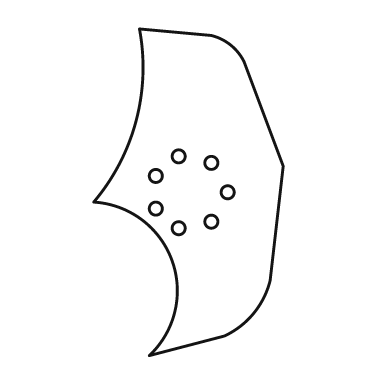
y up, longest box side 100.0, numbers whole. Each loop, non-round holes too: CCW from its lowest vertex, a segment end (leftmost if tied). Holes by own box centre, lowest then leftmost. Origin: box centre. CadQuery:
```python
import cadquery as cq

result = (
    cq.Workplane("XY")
    .moveTo(-12.0, -50.0)
    .lineTo(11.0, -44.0)
    .threePointArc((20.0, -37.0), (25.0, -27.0))
    .lineTo(29.0, 8.0)
    .lineTo(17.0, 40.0)
    .threePointArc((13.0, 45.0), (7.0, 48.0))
    .lineTo(-15.0, 50.0)
    .threePointArc((-16.0, 22.0), (-29.0, -3.0))
    .threePointArc((-5.0, -21.0), (-12.0, -50.0))
    .close()
    .moveTo(-3.0, -11.0)
    .circle(2.0)
    .moveTo(7.0, -9.0)
    .circle(2.0)
    .moveTo(-10.0, -5.0)
    .circle(2.0)
    .moveTo(12.0, 0.0)
    .circle(2.0)
    .moveTo(-10.0, 5.0)
    .circle(2.0)
    .moveTo(7.0, 9.0)
    .circle(2.0)
    .moveTo(-3.0, 11.0)
    .circle(2.0)
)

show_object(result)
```